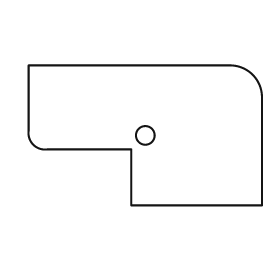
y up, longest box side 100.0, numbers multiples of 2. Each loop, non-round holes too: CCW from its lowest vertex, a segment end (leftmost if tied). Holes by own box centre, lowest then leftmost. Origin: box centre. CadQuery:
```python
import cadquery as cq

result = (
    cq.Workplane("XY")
    .moveTo(-6.0, -30.0)
    .lineTo(50.0, -30.0)
    .lineTo(50.0, 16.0)
    .threePointArc((46.0, 26.0), (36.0, 30.0))
    .lineTo(-50.0, 30.0)
    .lineTo(-50.0, 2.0)
    .threePointArc((-48.0, -4.0), (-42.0, -6.0))
    .lineTo(-6.0, -6.0)
    .close()
    .moveTo(0.0, 0.0)
    .circle(4.0)
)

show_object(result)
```